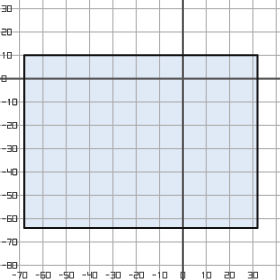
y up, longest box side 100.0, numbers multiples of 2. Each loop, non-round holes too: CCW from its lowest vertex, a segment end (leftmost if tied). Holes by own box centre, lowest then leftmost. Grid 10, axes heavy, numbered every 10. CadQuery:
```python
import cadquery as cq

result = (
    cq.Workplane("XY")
    .moveTo(-68.0, -64.0)
    .lineTo(32.0, -64.0)
    .lineTo(32.0, 10.0)
    .lineTo(-68.0, 10.0)
    .close()
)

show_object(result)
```